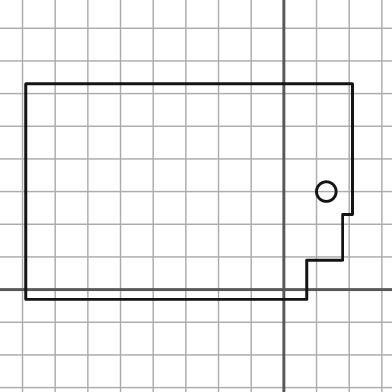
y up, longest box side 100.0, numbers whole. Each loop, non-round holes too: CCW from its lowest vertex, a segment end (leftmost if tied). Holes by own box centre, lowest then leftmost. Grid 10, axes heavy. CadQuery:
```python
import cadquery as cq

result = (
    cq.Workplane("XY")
    .moveTo(-79.0, -3.0)
    .lineTo(7.0, -3.0)
    .lineTo(7.0, 9.0)
    .lineTo(18.0, 9.0)
    .lineTo(18.0, 23.0)
    .lineTo(21.0, 23.0)
    .lineTo(21.0, 63.0)
    .lineTo(-79.0, 63.0)
    .close()
    .moveTo(13.0, 30.0)
    .circle(3.0)
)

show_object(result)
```